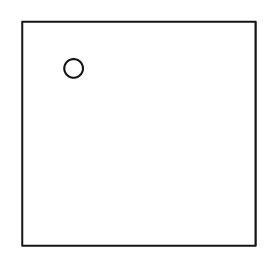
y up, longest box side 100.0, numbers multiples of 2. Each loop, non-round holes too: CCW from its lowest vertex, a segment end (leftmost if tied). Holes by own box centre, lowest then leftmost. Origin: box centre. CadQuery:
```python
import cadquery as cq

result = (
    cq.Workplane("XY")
    .moveTo(-50.0, -48.0)
    .lineTo(50.0, -48.0)
    .lineTo(50.0, 48.0)
    .lineTo(-50.0, 48.0)
    .close()
    .moveTo(-28.0, 28.0)
    .circle(4.0)
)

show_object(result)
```